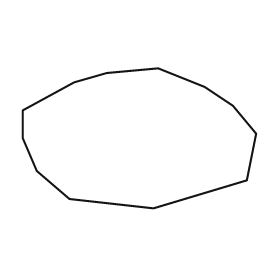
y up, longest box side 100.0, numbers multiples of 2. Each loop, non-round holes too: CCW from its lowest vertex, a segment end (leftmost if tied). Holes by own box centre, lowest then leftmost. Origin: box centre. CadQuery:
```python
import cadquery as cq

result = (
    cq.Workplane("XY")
    .moveTo(6.0, -30.0)
    .lineTo(46.0, -18.0)
    .lineTo(50.0, 2.0)
    .lineTo(40.0, 14.0)
    .lineTo(28.0, 22.0)
    .lineTo(8.0, 30.0)
    .lineTo(-14.0, 28.0)
    .lineTo(-28.0, 24.0)
    .lineTo(-50.0, 12.0)
    .lineTo(-50.0, 0.0)
    .lineTo(-44.0, -14.0)
    .lineTo(-30.0, -26.0)
    .close()
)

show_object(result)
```